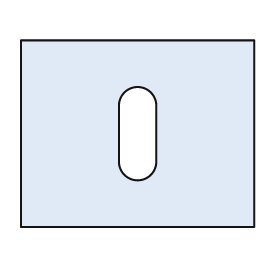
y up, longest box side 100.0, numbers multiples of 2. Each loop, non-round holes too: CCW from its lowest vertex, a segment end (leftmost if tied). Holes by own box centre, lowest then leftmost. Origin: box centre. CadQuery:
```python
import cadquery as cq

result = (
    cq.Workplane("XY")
    .moveTo(-50.0, -40.0)
    .lineTo(50.0, -40.0)
    .lineTo(50.0, 40.0)
    .lineTo(-50.0, 40.0)
    .close()
    .moveTo(-8.0, -12.0)
    .threePointArc((0.0, -20.0), (8.0, -12.0))
    .lineTo(8.0, 12.0)
    .threePointArc((0.0, 20.0), (-8.0, 12.0))
    .close()
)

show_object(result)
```